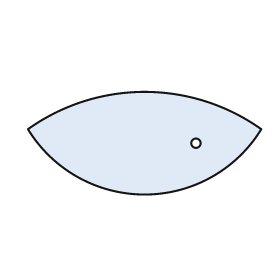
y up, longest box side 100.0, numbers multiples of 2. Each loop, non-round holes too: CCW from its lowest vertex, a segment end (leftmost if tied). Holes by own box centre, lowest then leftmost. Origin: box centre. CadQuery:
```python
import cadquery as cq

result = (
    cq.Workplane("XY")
    .moveTo(-50.0, 6.0)
    .threePointArc((0.0, -22.0), (50.0, 6.0))
    .threePointArc((0.0, 22.0), (-50.0, 6.0))
    .close()
    .moveTo(22.0, 0.0)
    .circle(2.0)
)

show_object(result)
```